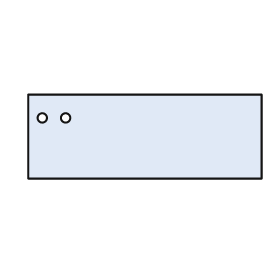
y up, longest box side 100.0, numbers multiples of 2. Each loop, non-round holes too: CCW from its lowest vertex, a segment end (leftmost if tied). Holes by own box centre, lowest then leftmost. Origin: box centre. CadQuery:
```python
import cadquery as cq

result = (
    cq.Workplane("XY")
    .moveTo(-50.0, -18.0)
    .lineTo(50.0, -18.0)
    .lineTo(50.0, 18.0)
    .lineTo(-50.0, 18.0)
    .close()
    .moveTo(-44.0, 8.0)
    .circle(2.0)
    .moveTo(-34.0, 8.0)
    .circle(2.0)
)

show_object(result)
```